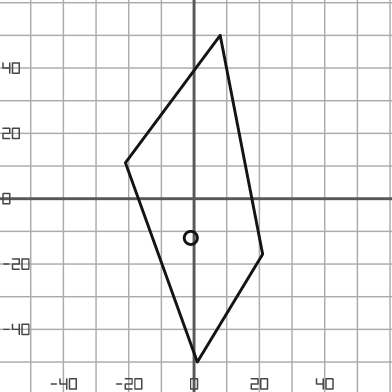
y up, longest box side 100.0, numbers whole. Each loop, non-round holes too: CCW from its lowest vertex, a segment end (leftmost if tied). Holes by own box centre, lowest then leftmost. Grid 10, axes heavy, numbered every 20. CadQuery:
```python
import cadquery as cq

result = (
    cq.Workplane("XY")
    .moveTo(1.0, -50.0)
    .lineTo(21.0, -17.0)
    .lineTo(8.0, 50.0)
    .lineTo(-21.0, 11.0)
    .close()
    .moveTo(-1.0, -12.0)
    .circle(2.0)
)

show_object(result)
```